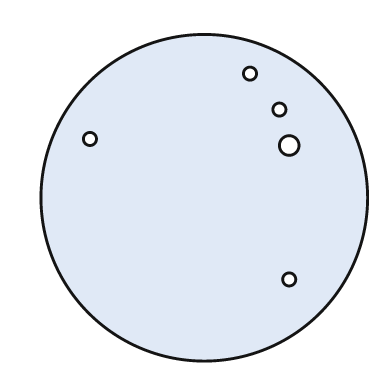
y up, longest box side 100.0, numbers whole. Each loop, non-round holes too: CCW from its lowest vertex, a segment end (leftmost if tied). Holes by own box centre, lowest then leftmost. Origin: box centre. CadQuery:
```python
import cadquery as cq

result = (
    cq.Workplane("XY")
    .moveTo(0.0, 0.0)
    .circle(50.0)
    .moveTo(26.0, -25.0)
    .circle(2.0)
    .moveTo(26.0, 16.0)
    .circle(3.0)
    .moveTo(-35.0, 18.0)
    .circle(2.0)
    .moveTo(23.0, 27.0)
    .circle(2.0)
    .moveTo(14.0, 38.0)
    .circle(2.0)
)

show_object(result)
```